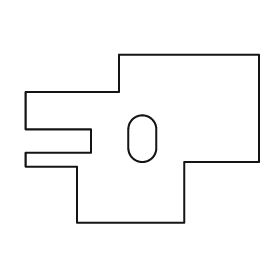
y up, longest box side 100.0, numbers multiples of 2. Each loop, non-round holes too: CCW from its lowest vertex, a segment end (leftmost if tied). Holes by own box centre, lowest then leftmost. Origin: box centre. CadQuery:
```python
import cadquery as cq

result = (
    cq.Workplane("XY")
    .moveTo(-28.0, -36.0)
    .lineTo(18.0, -36.0)
    .lineTo(18.0, -10.0)
    .lineTo(50.0, -10.0)
    .lineTo(50.0, 36.0)
    .lineTo(-10.0, 36.0)
    .lineTo(-10.0, 20.0)
    .lineTo(-50.0, 20.0)
    .lineTo(-50.0, 4.0)
    .lineTo(-22.0, 4.0)
    .lineTo(-22.0, -6.0)
    .lineTo(-50.0, -6.0)
    .lineTo(-50.0, -12.0)
    .lineTo(-28.0, -12.0)
    .close()
    .moveTo(-6.0, -4.0)
    .threePointArc((0.0, -10.0), (6.0, -4.0))
    .lineTo(6.0, 4.0)
    .threePointArc((0.0, 10.0), (-6.0, 4.0))
    .close()
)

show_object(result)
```